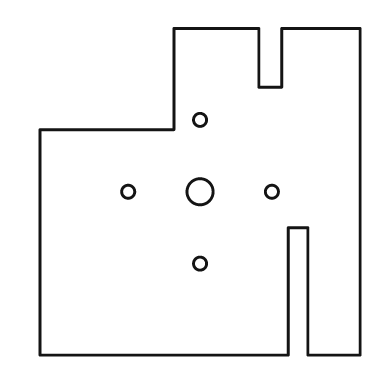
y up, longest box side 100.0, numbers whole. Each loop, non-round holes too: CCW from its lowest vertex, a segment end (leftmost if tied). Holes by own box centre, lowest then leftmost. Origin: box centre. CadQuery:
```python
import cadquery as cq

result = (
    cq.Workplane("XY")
    .moveTo(-49.0, -50.0)
    .lineTo(27.0, -50.0)
    .lineTo(27.0, -11.0)
    .lineTo(33.0, -11.0)
    .lineTo(33.0, -50.0)
    .lineTo(49.0, -50.0)
    .lineTo(49.0, 50.0)
    .lineTo(25.0, 50.0)
    .lineTo(25.0, 32.0)
    .lineTo(18.0, 32.0)
    .lineTo(18.0, 50.0)
    .lineTo(-8.0, 50.0)
    .lineTo(-8.0, 19.0)
    .lineTo(-49.0, 19.0)
    .close()
    .moveTo(0.0, -22.0)
    .circle(2.0)
    .moveTo(-22.0, 0.0)
    .circle(2.0)
    .moveTo(0.0, 0.0)
    .circle(4.0)
    .moveTo(22.0, 0.0)
    .circle(2.0)
    .moveTo(0.0, 22.0)
    .circle(2.0)
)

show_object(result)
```